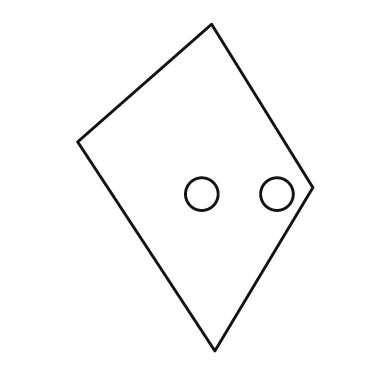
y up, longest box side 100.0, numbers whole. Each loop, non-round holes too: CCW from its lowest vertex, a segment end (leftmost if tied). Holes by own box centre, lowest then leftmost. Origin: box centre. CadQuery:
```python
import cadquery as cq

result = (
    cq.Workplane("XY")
    .moveTo(6.0, -50.0)
    .lineTo(36.0, 0.0)
    .lineTo(5.0, 50.0)
    .lineTo(-36.0, 14.0)
    .close()
    .moveTo(2.0, -2.0)
    .circle(5.0)
    .moveTo(25.0, -2.0)
    .circle(5.0)
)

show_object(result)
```